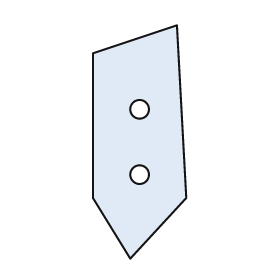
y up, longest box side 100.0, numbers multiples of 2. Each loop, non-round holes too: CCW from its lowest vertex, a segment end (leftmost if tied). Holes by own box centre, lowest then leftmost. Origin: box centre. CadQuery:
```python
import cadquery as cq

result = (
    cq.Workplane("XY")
    .moveTo(-4.0, -50.0)
    .lineTo(20.0, -24.0)
    .lineTo(16.0, 50.0)
    .lineTo(-20.0, 38.0)
    .lineTo(-20.0, -24.0)
    .close()
    .moveTo(0.0, -14.0)
    .circle(4.0)
    .moveTo(0.0, 14.0)
    .circle(4.0)
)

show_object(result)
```